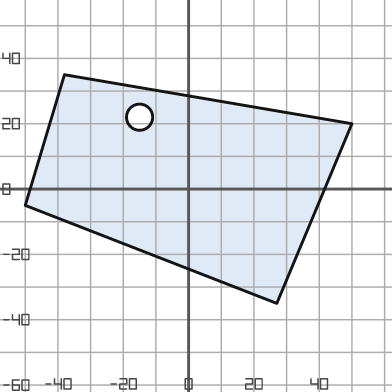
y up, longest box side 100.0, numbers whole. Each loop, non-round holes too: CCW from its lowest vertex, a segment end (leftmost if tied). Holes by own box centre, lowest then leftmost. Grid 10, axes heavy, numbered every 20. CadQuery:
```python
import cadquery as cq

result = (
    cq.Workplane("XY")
    .moveTo(27.0, -35.0)
    .lineTo(50.0, 20.0)
    .lineTo(-38.0, 35.0)
    .lineTo(-50.0, -5.0)
    .close()
    .moveTo(-15.0, 22.0)
    .circle(4.0)
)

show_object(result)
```